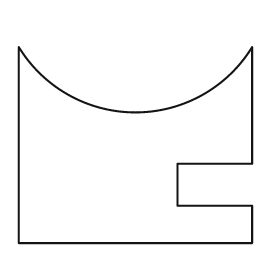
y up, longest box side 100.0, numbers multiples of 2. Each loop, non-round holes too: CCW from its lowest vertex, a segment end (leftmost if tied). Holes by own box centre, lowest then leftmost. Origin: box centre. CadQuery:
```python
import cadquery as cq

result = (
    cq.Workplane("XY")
    .moveTo(-50.0, -42.0)
    .lineTo(50.0, -42.0)
    .lineTo(50.0, -26.0)
    .lineTo(18.0, -26.0)
    .lineTo(18.0, -8.0)
    .lineTo(50.0, -8.0)
    .lineTo(50.0, 42.0)
    .threePointArc((0.0, 14.0), (-50.0, 42.0))
    .close()
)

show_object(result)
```